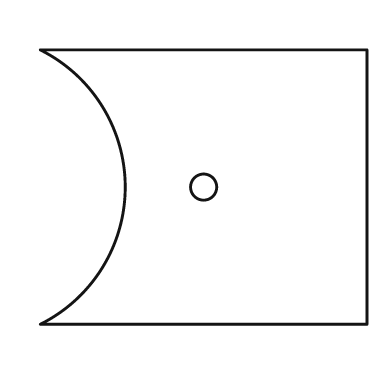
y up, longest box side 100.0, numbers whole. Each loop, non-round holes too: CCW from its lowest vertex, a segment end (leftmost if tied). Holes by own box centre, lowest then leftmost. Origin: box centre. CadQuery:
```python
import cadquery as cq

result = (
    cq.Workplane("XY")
    .moveTo(-50.0, -42.0)
    .lineTo(50.0, -42.0)
    .lineTo(50.0, 42.0)
    .lineTo(-50.0, 42.0)
    .threePointArc((-24.0, 0.0), (-50.0, -42.0))
    .close()
    .moveTo(0.0, 0.0)
    .circle(4.0)
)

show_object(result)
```